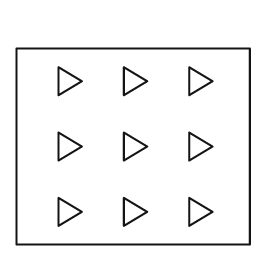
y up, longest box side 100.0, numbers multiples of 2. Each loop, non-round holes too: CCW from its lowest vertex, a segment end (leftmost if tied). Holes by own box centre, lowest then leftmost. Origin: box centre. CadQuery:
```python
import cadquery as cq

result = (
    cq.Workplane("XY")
    .moveTo(-50.0, -42.0)
    .lineTo(50.0, -42.0)
    .lineTo(50.0, 42.0)
    .lineTo(-50.0, 42.0)
    .close()
    .moveTo(-32.0, -34.0)
    .lineTo(-22.0, -28.0)
    .lineTo(-32.0, -22.0)
    .close()
    .moveTo(-4.0, -34.0)
    .lineTo(6.0, -28.0)
    .lineTo(-4.0, -22.0)
    .close()
    .moveTo(24.0, -34.0)
    .lineTo(34.0, -28.0)
    .lineTo(24.0, -22.0)
    .close()
    .moveTo(-32.0, -6.0)
    .lineTo(-22.0, 0.0)
    .lineTo(-32.0, 6.0)
    .close()
    .moveTo(-4.0, -6.0)
    .lineTo(6.0, 0.0)
    .lineTo(-4.0, 6.0)
    .close()
    .moveTo(24.0, -6.0)
    .lineTo(34.0, 0.0)
    .lineTo(24.0, 6.0)
    .close()
    .moveTo(-32.0, 22.0)
    .lineTo(-22.0, 28.0)
    .lineTo(-32.0, 34.0)
    .close()
    .moveTo(-4.0, 22.0)
    .lineTo(6.0, 28.0)
    .lineTo(-4.0, 34.0)
    .close()
    .moveTo(24.0, 22.0)
    .lineTo(34.0, 28.0)
    .lineTo(24.0, 34.0)
    .close()
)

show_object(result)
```